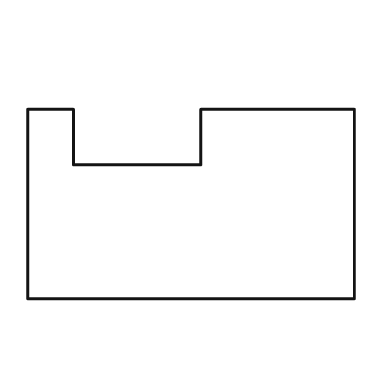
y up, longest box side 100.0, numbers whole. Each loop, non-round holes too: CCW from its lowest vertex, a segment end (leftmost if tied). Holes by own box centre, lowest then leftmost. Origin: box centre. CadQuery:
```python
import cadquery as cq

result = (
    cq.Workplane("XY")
    .moveTo(-50.0, -29.0)
    .lineTo(50.0, -29.0)
    .lineTo(50.0, 29.0)
    .lineTo(3.0, 29.0)
    .lineTo(3.0, 12.0)
    .lineTo(-36.0, 12.0)
    .lineTo(-36.0, 29.0)
    .lineTo(-50.0, 29.0)
    .close()
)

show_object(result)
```